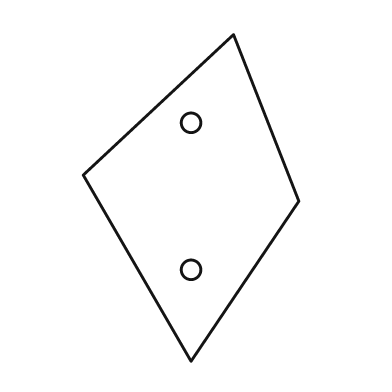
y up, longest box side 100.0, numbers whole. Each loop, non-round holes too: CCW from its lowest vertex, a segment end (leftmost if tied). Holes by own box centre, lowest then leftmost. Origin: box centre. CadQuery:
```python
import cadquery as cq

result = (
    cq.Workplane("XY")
    .moveTo(0.0, -50.0)
    .lineTo(33.0, -1.0)
    .lineTo(13.0, 50.0)
    .lineTo(-33.0, 7.0)
    .close()
    .moveTo(0.0, -22.0)
    .circle(3.0)
    .moveTo(0.0, 23.0)
    .circle(3.0)
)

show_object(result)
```